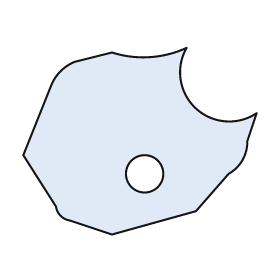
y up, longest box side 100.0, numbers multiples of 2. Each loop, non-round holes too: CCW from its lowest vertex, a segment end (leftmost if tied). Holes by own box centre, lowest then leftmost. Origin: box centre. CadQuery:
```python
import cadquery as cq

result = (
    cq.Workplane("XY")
    .moveTo(-12.0, -40.0)
    .lineTo(24.0, -30.0)
    .lineTo(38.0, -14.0)
    .threePointArc((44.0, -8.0), (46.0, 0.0))
    .lineTo(50.0, 12.0)
    .threePointArc((24.0, 14.0), (20.0, 40.0))
    .threePointArc((4.0, 36.0), (-12.0, 38.0))
    .lineTo(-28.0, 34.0)
    .threePointArc((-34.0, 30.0), (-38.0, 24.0))
    .lineTo(-50.0, -6.0)
    .lineTo(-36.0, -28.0)
    .threePointArc((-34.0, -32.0), (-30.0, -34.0))
    .close()
    .moveTo(2.0, -14.0)
    .circle(8.0)
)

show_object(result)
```